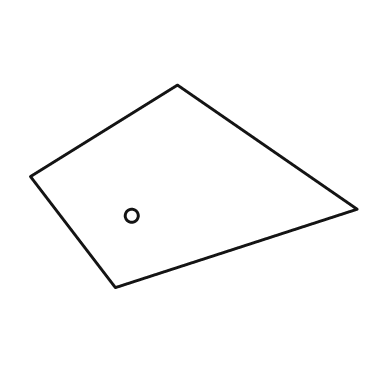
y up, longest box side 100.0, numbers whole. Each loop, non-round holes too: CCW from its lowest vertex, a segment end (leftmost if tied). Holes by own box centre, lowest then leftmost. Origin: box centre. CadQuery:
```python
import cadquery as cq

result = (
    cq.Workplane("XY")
    .moveTo(-24.0, -31.0)
    .lineTo(50.0, -7.0)
    .lineTo(-5.0, 31.0)
    .lineTo(-50.0, 3.0)
    .close()
    .moveTo(-19.0, -9.0)
    .circle(2.0)
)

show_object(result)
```